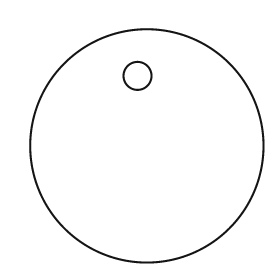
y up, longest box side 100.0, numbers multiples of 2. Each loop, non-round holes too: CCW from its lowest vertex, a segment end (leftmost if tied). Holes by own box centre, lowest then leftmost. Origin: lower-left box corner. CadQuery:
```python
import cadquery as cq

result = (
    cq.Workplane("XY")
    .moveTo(50.0, 50.0)
    .circle(50.0)
    .moveTo(46.0, 80.0)
    .circle(6.0)
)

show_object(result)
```